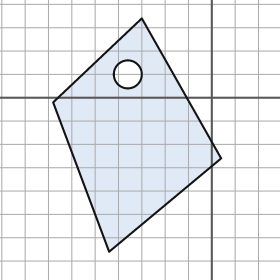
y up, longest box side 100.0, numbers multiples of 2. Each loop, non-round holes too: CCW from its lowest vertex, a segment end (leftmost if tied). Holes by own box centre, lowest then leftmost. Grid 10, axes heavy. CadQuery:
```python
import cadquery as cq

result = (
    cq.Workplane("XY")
    .moveTo(-44.0, -66.0)
    .lineTo(4.0, -26.0)
    .lineTo(-30.0, 34.0)
    .lineTo(-68.0, -2.0)
    .close()
    .moveTo(-36.0, 10.0)
    .circle(6.0)
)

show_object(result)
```